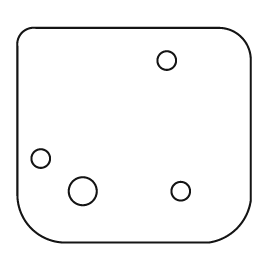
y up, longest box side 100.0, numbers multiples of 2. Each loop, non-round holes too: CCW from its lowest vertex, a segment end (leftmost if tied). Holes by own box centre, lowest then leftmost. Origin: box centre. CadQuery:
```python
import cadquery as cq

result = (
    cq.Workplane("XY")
    .moveTo(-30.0, -46.0)
    .lineTo(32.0, -46.0)
    .threePointArc((44.0, -40.0), (50.0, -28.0))
    .lineTo(50.0, 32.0)
    .threePointArc((46.0, 42.0), (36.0, 46.0))
    .lineTo(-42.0, 46.0)
    .threePointArc((-48.0, 44.0), (-50.0, 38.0))
    .lineTo(-50.0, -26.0)
    .threePointArc((-44.0, -40.0), (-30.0, -46.0))
    .close()
    .moveTo(-22.0, -24.0)
    .circle(6.0)
    .moveTo(20.0, -24.0)
    .circle(4.0)
    .moveTo(-40.0, -10.0)
    .circle(4.0)
    .moveTo(14.0, 32.0)
    .circle(4.0)
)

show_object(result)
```